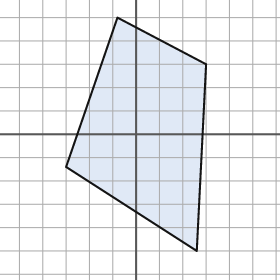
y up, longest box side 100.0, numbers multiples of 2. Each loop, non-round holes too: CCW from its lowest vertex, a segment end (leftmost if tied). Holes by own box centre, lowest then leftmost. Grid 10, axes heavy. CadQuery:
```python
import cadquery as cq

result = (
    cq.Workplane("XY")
    .moveTo(26.0, -50.0)
    .lineTo(30.0, 30.0)
    .lineTo(-8.0, 50.0)
    .lineTo(-30.0, -14.0)
    .close()
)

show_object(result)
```